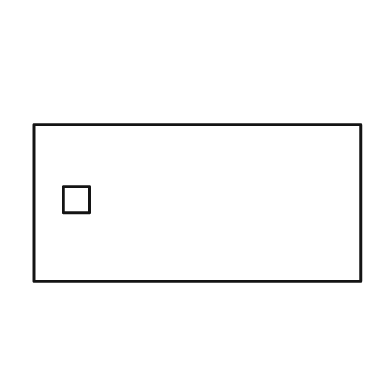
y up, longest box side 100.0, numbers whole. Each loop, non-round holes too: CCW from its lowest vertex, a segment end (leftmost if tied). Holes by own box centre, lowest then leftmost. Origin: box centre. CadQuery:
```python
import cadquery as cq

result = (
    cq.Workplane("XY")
    .moveTo(-50.0, -24.0)
    .lineTo(50.0, -24.0)
    .lineTo(50.0, 24.0)
    .lineTo(-50.0, 24.0)
    .close()
    .moveTo(-41.0, -3.0)
    .lineTo(-33.0, -3.0)
    .lineTo(-33.0, 5.0)
    .lineTo(-41.0, 5.0)
    .close()
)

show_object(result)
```